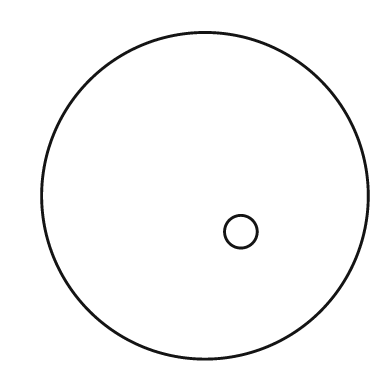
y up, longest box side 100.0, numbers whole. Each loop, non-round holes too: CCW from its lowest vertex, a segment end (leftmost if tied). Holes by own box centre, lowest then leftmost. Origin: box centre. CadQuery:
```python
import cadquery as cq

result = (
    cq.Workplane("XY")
    .moveTo(0.0, 0.0)
    .circle(50.0)
    .moveTo(11.0, -11.0)
    .circle(5.0)
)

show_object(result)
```